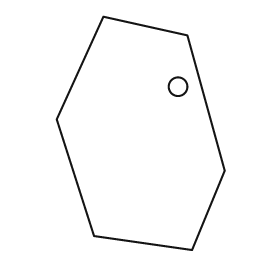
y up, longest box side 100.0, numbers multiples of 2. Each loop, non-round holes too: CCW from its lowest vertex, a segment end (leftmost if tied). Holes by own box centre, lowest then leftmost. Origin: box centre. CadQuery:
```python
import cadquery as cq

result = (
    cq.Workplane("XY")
    .moveTo(22.0, -50.0)
    .lineTo(36.0, -16.0)
    .lineTo(20.0, 42.0)
    .lineTo(-16.0, 50.0)
    .lineTo(-36.0, 6.0)
    .lineTo(-20.0, -44.0)
    .close()
    .moveTo(16.0, 20.0)
    .circle(4.0)
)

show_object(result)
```